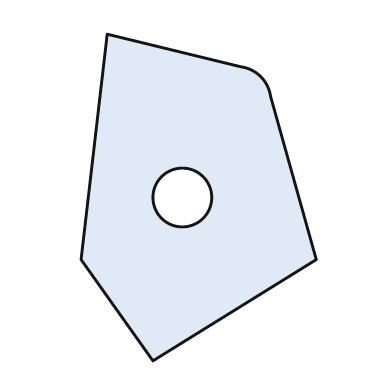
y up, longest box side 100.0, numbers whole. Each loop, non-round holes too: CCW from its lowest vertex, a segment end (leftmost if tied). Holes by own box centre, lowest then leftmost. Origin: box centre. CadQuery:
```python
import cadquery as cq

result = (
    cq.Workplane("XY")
    .moveTo(-14.0, -50.0)
    .lineTo(36.0, -19.0)
    .lineTo(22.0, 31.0)
    .threePointArc((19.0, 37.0), (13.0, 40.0))
    .lineTo(-28.0, 50.0)
    .lineTo(-36.0, -19.0)
    .close()
    .moveTo(-5.0, 0.0)
    .circle(9.0)
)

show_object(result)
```